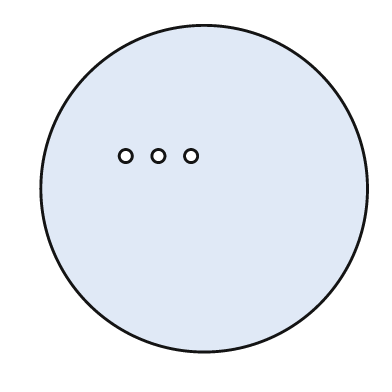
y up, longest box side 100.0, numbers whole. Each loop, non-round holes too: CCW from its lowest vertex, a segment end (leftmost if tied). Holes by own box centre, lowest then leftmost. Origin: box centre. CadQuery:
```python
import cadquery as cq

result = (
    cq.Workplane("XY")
    .moveTo(0.0, 0.0)
    .circle(50.0)
    .moveTo(-24.0, 10.0)
    .circle(2.0)
    .moveTo(-14.0, 10.0)
    .circle(2.0)
    .moveTo(-4.0, 10.0)
    .circle(2.0)
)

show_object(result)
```